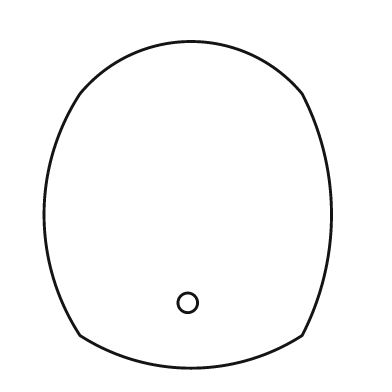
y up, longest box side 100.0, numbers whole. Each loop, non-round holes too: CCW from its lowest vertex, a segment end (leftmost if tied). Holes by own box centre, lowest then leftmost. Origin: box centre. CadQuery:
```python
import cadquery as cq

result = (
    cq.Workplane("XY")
    .moveTo(-33.0, -40.0)
    .threePointArc((1.0, -50.0), (35.0, -40.0))
    .threePointArc((44.0, -3.0), (35.0, 34.0))
    .threePointArc((1.0, 50.0), (-33.0, 34.0))
    .threePointArc((-44.0, -3.0), (-33.0, -40.0))
    .close()
    .moveTo(0.0, -30.0)
    .circle(3.0)
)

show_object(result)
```